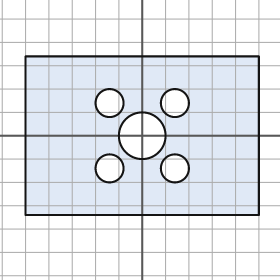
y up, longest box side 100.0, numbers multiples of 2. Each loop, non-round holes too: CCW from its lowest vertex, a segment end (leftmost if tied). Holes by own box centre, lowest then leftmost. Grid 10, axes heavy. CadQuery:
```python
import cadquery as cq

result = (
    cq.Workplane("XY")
    .moveTo(-50.0, -34.0)
    .lineTo(50.0, -34.0)
    .lineTo(50.0, 34.0)
    .lineTo(-50.0, 34.0)
    .close()
    .moveTo(-14.0, -14.0)
    .circle(6.0)
    .moveTo(14.0, -14.0)
    .circle(6.0)
    .moveTo(0.0, 0.0)
    .circle(10.0)
    .moveTo(-14.0, 14.0)
    .circle(6.0)
    .moveTo(14.0, 14.0)
    .circle(6.0)
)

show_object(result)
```